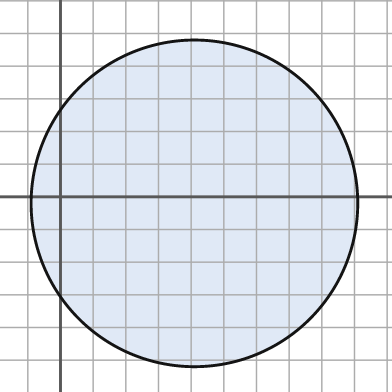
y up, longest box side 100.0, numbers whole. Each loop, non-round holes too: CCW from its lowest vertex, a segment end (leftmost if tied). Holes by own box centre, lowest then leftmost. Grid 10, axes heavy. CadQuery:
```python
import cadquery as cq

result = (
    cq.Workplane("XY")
    .moveTo(41.0, -2.0)
    .circle(50.0)
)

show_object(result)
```